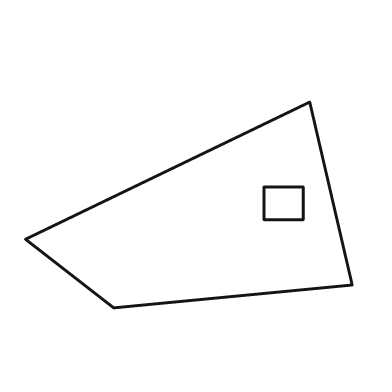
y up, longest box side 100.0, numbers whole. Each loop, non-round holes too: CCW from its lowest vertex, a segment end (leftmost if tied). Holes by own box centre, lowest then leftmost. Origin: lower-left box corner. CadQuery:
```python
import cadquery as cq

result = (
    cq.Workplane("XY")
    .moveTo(27.0, 0.0)
    .lineTo(100.0, 7.0)
    .lineTo(87.0, 63.0)
    .lineTo(0.0, 21.0)
    .close()
    .moveTo(73.0, 27.0)
    .lineTo(85.0, 27.0)
    .lineTo(85.0, 37.0)
    .lineTo(73.0, 37.0)
    .close()
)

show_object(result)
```